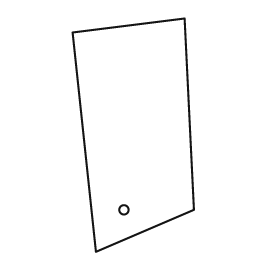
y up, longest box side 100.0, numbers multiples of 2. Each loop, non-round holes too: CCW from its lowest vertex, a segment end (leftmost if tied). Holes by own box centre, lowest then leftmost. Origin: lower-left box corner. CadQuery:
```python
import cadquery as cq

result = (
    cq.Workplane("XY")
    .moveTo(10.0, 0.0)
    .lineTo(52.0, 18.0)
    .lineTo(48.0, 100.0)
    .lineTo(0.0, 94.0)
    .close()
    .moveTo(22.0, 18.0)
    .circle(2.0)
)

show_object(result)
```